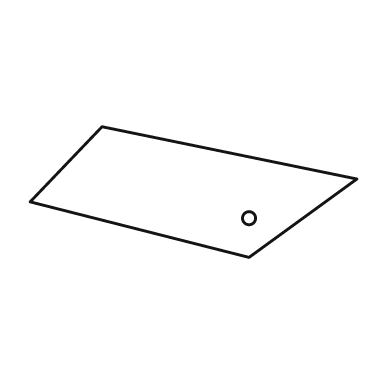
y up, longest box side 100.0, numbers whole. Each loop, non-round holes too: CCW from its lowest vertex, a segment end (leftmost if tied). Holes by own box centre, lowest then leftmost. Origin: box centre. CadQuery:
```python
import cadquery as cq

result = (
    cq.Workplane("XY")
    .moveTo(17.0, -20.0)
    .lineTo(50.0, 4.0)
    .lineTo(-28.0, 20.0)
    .lineTo(-50.0, -3.0)
    .close()
    .moveTo(17.0, -8.0)
    .circle(2.0)
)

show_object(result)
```